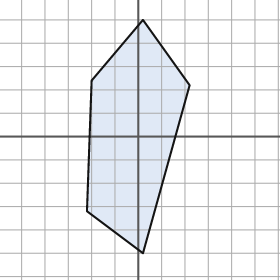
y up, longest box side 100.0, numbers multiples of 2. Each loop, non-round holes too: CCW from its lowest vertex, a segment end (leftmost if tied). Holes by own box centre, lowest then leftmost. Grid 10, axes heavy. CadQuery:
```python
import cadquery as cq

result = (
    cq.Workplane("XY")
    .moveTo(2.0, -50.0)
    .lineTo(22.0, 22.0)
    .lineTo(2.0, 50.0)
    .lineTo(-20.0, 24.0)
    .lineTo(-22.0, -32.0)
    .close()
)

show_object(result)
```